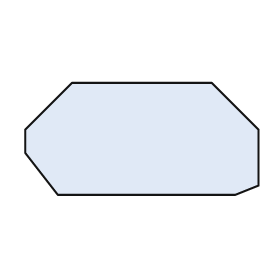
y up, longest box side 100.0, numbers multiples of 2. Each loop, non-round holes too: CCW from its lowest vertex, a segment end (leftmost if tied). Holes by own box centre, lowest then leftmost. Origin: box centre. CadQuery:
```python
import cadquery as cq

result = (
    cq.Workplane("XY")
    .moveTo(-36.0, -24.0)
    .lineTo(40.0, -24.0)
    .lineTo(50.0, -20.0)
    .lineTo(50.0, 4.0)
    .lineTo(30.0, 24.0)
    .lineTo(-30.0, 24.0)
    .lineTo(-50.0, 4.0)
    .lineTo(-50.0, -6.0)
    .close()
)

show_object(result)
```